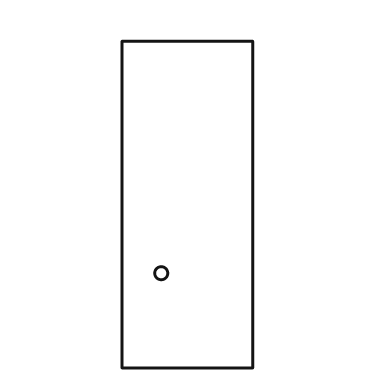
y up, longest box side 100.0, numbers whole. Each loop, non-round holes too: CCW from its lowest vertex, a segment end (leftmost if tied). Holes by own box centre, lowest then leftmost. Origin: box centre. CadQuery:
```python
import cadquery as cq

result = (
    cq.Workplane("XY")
    .moveTo(-20.0, -50.0)
    .lineTo(20.0, -50.0)
    .lineTo(20.0, 50.0)
    .lineTo(-20.0, 50.0)
    .close()
    .moveTo(-8.0, -21.0)
    .circle(2.0)
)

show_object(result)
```